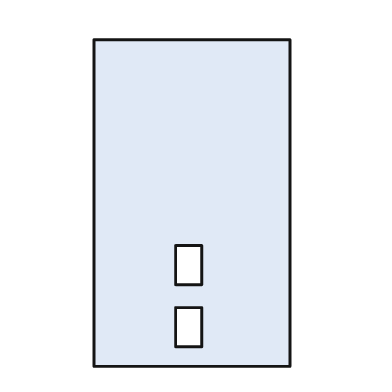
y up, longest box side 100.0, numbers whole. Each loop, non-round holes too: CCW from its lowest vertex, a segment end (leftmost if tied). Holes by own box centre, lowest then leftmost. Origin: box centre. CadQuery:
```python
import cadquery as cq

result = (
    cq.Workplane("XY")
    .moveTo(-30.0, -50.0)
    .lineTo(30.0, -50.0)
    .lineTo(30.0, 50.0)
    .lineTo(-30.0, 50.0)
    .close()
    .moveTo(-5.0, -44.0)
    .lineTo(3.0, -44.0)
    .lineTo(3.0, -32.0)
    .lineTo(-5.0, -32.0)
    .close()
    .moveTo(-5.0, -25.0)
    .lineTo(3.0, -25.0)
    .lineTo(3.0, -13.0)
    .lineTo(-5.0, -13.0)
    .close()
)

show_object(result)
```